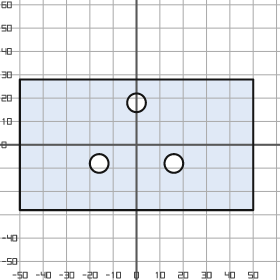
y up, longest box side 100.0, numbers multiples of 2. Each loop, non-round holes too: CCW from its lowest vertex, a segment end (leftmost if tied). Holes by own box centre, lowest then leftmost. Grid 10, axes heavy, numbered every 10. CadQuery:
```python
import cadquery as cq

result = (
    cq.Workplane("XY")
    .moveTo(-50.0, -28.0)
    .lineTo(50.0, -28.0)
    .lineTo(50.0, 28.0)
    .lineTo(-50.0, 28.0)
    .close()
    .moveTo(-16.0, -8.0)
    .circle(4.0)
    .moveTo(16.0, -8.0)
    .circle(4.0)
    .moveTo(0.0, 18.0)
    .circle(4.0)
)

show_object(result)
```